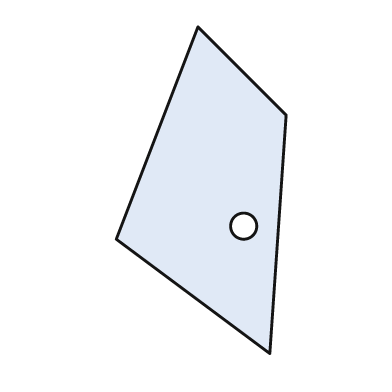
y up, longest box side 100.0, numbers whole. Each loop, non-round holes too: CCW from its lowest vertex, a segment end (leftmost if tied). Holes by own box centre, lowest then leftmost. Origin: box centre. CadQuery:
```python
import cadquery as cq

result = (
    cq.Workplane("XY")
    .moveTo(21.0, -50.0)
    .lineTo(26.0, 23.0)
    .lineTo(-1.0, 50.0)
    .lineTo(-26.0, -15.0)
    .close()
    .moveTo(13.0, -11.0)
    .circle(4.0)
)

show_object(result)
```